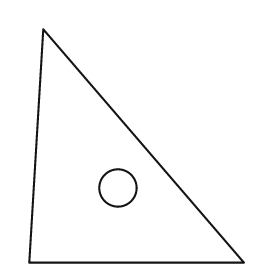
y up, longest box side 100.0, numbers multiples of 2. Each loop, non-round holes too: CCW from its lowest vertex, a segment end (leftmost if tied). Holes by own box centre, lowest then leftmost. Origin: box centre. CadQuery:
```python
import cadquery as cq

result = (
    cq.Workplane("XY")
    .moveTo(-46.0, -50.0)
    .lineTo(46.0, -50.0)
    .lineTo(-40.0, 50.0)
    .close()
    .moveTo(-8.0, -18.0)
    .circle(8.0)
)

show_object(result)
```